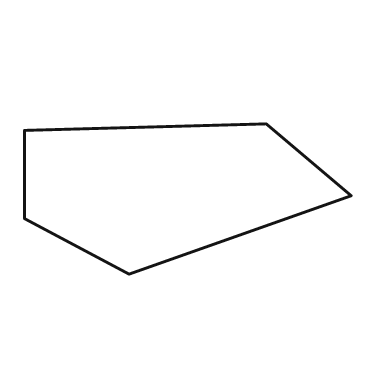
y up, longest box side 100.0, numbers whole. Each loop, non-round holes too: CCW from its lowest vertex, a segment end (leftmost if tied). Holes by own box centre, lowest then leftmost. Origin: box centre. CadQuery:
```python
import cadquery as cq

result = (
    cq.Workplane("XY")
    .moveTo(-18.0, -23.0)
    .lineTo(50.0, 1.0)
    .lineTo(24.0, 23.0)
    .lineTo(-50.0, 21.0)
    .lineTo(-50.0, -6.0)
    .close()
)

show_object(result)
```